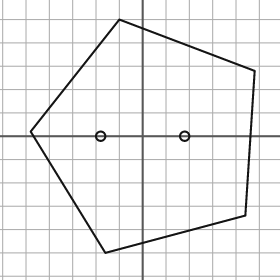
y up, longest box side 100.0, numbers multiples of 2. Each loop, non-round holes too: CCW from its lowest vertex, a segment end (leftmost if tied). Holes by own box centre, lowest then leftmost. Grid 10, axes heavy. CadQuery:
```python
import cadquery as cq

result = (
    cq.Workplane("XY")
    .moveTo(-16.0, -50.0)
    .lineTo(44.0, -34.0)
    .lineTo(48.0, 28.0)
    .lineTo(-10.0, 50.0)
    .lineTo(-48.0, 2.0)
    .close()
    .moveTo(-18.0, 0.0)
    .circle(2.0)
    .moveTo(18.0, 0.0)
    .circle(2.0)
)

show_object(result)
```